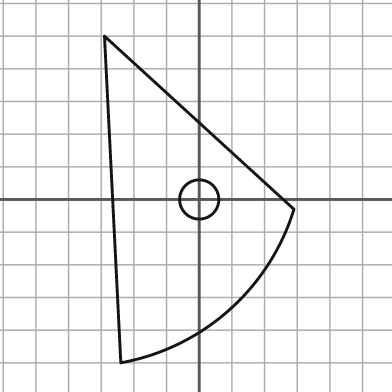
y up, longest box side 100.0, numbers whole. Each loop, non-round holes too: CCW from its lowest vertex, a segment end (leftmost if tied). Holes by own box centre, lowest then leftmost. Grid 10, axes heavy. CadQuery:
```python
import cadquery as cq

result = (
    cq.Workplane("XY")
    .moveTo(-24.0, -50.0)
    .threePointArc((9.0, -34.0), (29.0, -3.0))
    .lineTo(-29.0, 50.0)
    .close()
    .moveTo(0.0, 0.0)
    .circle(6.0)
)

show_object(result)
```